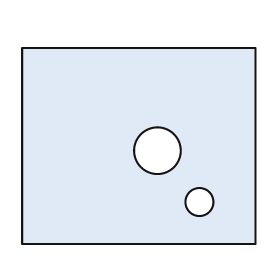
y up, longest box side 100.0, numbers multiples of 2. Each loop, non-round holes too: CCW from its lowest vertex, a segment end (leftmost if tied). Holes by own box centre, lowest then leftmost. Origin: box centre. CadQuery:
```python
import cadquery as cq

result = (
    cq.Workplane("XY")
    .moveTo(-50.0, -42.0)
    .lineTo(50.0, -42.0)
    .lineTo(50.0, 42.0)
    .lineTo(-50.0, 42.0)
    .close()
    .moveTo(26.0, -24.0)
    .circle(6.0)
    .moveTo(8.0, -2.0)
    .circle(10.0)
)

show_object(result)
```